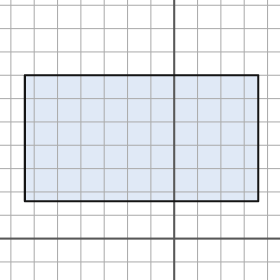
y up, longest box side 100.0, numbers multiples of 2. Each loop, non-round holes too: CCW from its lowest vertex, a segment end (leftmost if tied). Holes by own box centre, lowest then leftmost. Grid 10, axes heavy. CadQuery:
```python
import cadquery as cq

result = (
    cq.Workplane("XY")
    .moveTo(-64.0, 16.0)
    .lineTo(36.0, 16.0)
    .lineTo(36.0, 70.0)
    .lineTo(-64.0, 70.0)
    .close()
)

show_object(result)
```